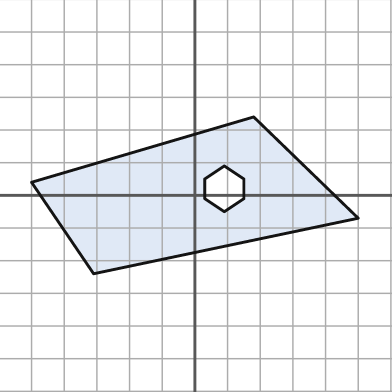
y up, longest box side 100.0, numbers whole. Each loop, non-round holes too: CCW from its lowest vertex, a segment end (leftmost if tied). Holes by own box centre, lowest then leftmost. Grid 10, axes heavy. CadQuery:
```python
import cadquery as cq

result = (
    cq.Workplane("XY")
    .moveTo(-31.0, -24.0)
    .lineTo(50.0, -7.0)
    .lineTo(18.0, 24.0)
    .lineTo(-50.0, 4.0)
    .close()
    .moveTo(9.0, -5.0)
    .lineTo(15.0, -1.0)
    .lineTo(15.0, 5.0)
    .lineTo(9.0, 9.0)
    .lineTo(3.0, 5.0)
    .lineTo(3.0, -1.0)
    .close()
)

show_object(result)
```